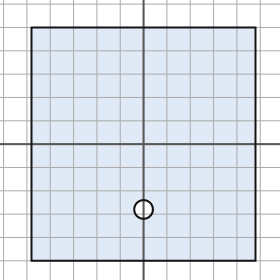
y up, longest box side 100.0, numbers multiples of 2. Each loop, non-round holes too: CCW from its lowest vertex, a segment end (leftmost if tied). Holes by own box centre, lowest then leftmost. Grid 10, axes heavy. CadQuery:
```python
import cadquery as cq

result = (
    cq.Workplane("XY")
    .moveTo(-48.0, -50.0)
    .lineTo(48.0, -50.0)
    .lineTo(48.0, 50.0)
    .lineTo(-48.0, 50.0)
    .close()
    .moveTo(0.0, -28.0)
    .circle(4.0)
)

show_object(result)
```